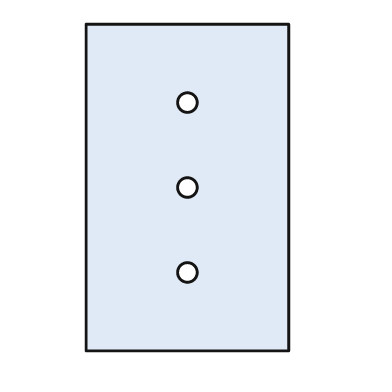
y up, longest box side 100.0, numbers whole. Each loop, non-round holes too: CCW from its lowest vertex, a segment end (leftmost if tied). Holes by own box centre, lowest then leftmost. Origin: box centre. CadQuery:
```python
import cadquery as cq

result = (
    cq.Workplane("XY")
    .moveTo(-31.0, -50.0)
    .lineTo(31.0, -50.0)
    .lineTo(31.0, 50.0)
    .lineTo(-31.0, 50.0)
    .close()
    .moveTo(0.0, -26.0)
    .circle(3.0)
    .moveTo(0.0, 0.0)
    .circle(3.0)
    .moveTo(0.0, 26.0)
    .circle(3.0)
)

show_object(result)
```